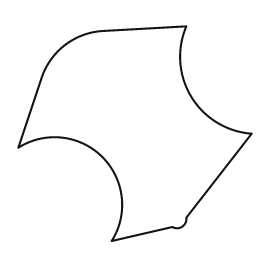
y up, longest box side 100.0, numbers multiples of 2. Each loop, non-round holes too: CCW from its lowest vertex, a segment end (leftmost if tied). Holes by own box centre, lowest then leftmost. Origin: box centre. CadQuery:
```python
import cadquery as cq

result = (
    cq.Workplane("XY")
    .moveTo(-10.0, -46.0)
    .lineTo(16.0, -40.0)
    .threePointArc((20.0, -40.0), (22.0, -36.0))
    .lineTo(50.0, 0.0)
    .threePointArc((24.0, 16.0), (22.0, 46.0))
    .lineTo(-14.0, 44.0)
    .threePointArc((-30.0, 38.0), (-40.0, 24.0))
    .lineTo(-50.0, -6.0)
    .threePointArc((-14.0, -10.0), (-10.0, -46.0))
    .close()
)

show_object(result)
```